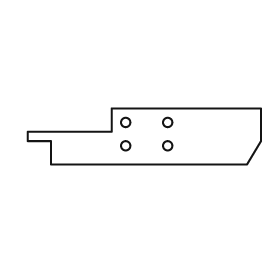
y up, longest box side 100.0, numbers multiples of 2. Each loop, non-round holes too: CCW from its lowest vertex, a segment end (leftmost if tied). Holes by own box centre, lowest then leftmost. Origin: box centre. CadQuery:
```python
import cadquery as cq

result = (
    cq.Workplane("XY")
    .moveTo(-40.0, -12.0)
    .lineTo(44.0, -12.0)
    .lineTo(50.0, -2.0)
    .lineTo(50.0, 12.0)
    .lineTo(-14.0, 12.0)
    .lineTo(-14.0, 2.0)
    .lineTo(-50.0, 2.0)
    .lineTo(-50.0, -2.0)
    .lineTo(-40.0, -2.0)
    .close()
    .moveTo(-8.0, -4.0)
    .circle(2.0)
    .moveTo(10.0, -4.0)
    .circle(2.0)
    .moveTo(-8.0, 6.0)
    .circle(2.0)
    .moveTo(10.0, 6.0)
    .circle(2.0)
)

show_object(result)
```